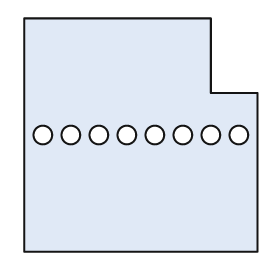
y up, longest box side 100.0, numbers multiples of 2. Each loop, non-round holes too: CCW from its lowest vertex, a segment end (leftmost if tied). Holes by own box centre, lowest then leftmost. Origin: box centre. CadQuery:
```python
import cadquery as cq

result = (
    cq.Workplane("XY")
    .moveTo(-50.0, -50.0)
    .lineTo(50.0, -50.0)
    .lineTo(50.0, 18.0)
    .lineTo(30.0, 18.0)
    .lineTo(30.0, 50.0)
    .lineTo(-50.0, 50.0)
    .close()
    .moveTo(-42.0, 0.0)
    .circle(4.0)
    .moveTo(-30.0, 0.0)
    .circle(4.0)
    .moveTo(-18.0, 0.0)
    .circle(4.0)
    .moveTo(-6.0, 0.0)
    .circle(4.0)
    .moveTo(6.0, 0.0)
    .circle(4.0)
    .moveTo(18.0, 0.0)
    .circle(4.0)
    .moveTo(30.0, 0.0)
    .circle(4.0)
    .moveTo(42.0, 0.0)
    .circle(4.0)
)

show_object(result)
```